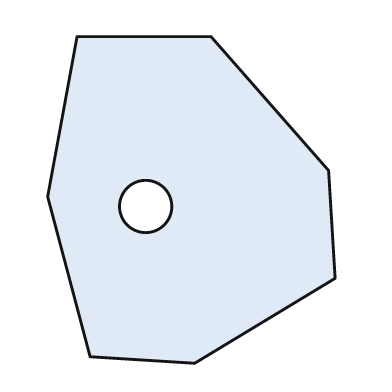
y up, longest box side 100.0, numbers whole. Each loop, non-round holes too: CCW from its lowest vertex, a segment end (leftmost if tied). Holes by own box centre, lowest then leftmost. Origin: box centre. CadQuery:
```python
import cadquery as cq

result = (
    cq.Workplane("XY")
    .moveTo(1.0, -50.0)
    .lineTo(44.0, -24.0)
    .lineTo(42.0, 9.0)
    .lineTo(6.0, 50.0)
    .lineTo(-35.0, 50.0)
    .lineTo(-44.0, 1.0)
    .lineTo(-31.0, -48.0)
    .close()
    .moveTo(-14.0, -2.0)
    .circle(8.0)
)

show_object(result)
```